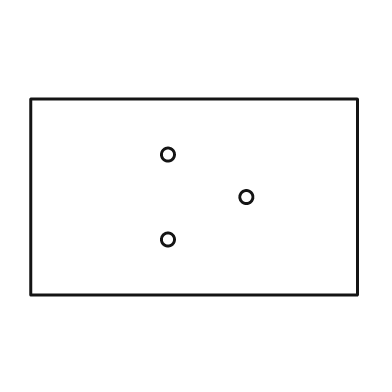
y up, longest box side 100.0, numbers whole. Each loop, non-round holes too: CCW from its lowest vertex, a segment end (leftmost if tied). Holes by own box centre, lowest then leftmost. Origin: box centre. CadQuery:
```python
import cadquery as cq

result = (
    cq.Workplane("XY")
    .moveTo(-50.0, -30.0)
    .lineTo(50.0, -30.0)
    .lineTo(50.0, 30.0)
    .lineTo(-50.0, 30.0)
    .close()
    .moveTo(-8.0, -13.0)
    .circle(2.0)
    .moveTo(16.0, 0.0)
    .circle(2.0)
    .moveTo(-8.0, 13.0)
    .circle(2.0)
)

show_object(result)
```